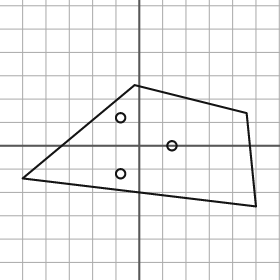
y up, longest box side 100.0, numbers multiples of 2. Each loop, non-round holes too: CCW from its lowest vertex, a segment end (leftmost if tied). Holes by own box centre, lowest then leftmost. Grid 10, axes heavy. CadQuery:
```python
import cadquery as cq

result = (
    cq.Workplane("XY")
    .moveTo(50.0, -26.0)
    .lineTo(46.0, 14.0)
    .lineTo(-2.0, 26.0)
    .lineTo(-50.0, -14.0)
    .close()
    .moveTo(-8.0, -12.0)
    .circle(2.0)
    .moveTo(14.0, 0.0)
    .circle(2.0)
    .moveTo(-8.0, 12.0)
    .circle(2.0)
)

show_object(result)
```